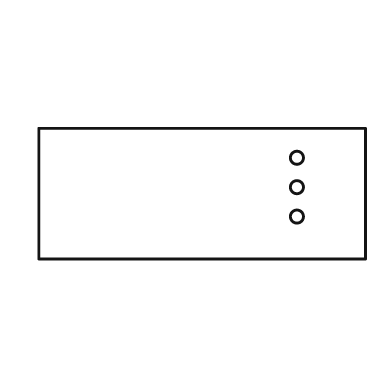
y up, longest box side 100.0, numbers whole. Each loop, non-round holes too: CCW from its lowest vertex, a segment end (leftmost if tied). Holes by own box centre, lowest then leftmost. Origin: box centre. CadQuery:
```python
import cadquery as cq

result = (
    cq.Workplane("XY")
    .moveTo(-50.0, -20.0)
    .lineTo(50.0, -20.0)
    .lineTo(50.0, 20.0)
    .lineTo(-50.0, 20.0)
    .close()
    .moveTo(29.0, -7.0)
    .circle(2.0)
    .moveTo(29.0, 2.0)
    .circle(2.0)
    .moveTo(29.0, 11.0)
    .circle(2.0)
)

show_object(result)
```